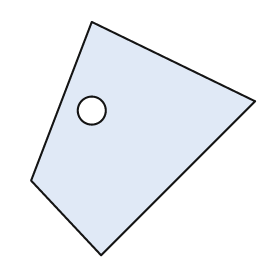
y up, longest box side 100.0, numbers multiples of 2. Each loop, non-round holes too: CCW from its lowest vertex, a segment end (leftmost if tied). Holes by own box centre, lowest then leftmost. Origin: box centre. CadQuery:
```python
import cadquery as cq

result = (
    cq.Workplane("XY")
    .moveTo(-18.0, -50.0)
    .lineTo(48.0, 16.0)
    .lineTo(-22.0, 50.0)
    .lineTo(-48.0, -18.0)
    .close()
    .moveTo(-22.0, 12.0)
    .circle(6.0)
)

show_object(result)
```